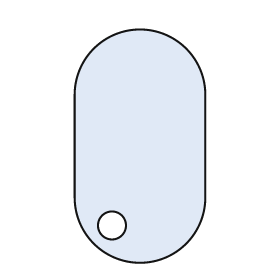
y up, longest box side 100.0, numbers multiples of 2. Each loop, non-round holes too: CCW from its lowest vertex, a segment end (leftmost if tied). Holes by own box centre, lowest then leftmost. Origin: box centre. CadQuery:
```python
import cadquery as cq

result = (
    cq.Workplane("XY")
    .moveTo(-28.0, -22.0)
    .threePointArc((0.0, -50.0), (28.0, -22.0))
    .lineTo(28.0, 22.0)
    .threePointArc((0.0, 50.0), (-28.0, 22.0))
    .close()
    .moveTo(-12.0, -34.0)
    .circle(6.0)
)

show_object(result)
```